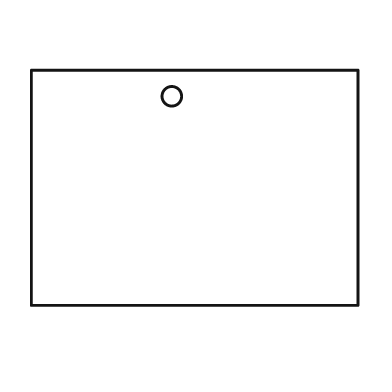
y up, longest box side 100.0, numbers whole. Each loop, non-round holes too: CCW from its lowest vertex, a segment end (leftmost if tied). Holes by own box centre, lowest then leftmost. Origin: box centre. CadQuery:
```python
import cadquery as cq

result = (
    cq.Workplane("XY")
    .moveTo(-50.0, -36.0)
    .lineTo(50.0, -36.0)
    .lineTo(50.0, 36.0)
    .lineTo(-50.0, 36.0)
    .close()
    .moveTo(-7.0, 28.0)
    .circle(3.0)
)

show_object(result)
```